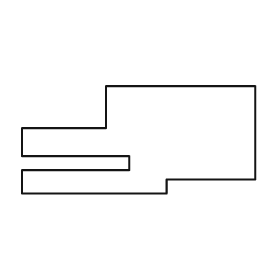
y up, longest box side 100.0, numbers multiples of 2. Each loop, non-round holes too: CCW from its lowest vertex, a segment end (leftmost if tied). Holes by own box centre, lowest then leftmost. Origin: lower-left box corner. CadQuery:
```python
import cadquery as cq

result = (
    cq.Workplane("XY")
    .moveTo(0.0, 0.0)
    .lineTo(62.0, 0.0)
    .lineTo(62.0, 6.0)
    .lineTo(100.0, 6.0)
    .lineTo(100.0, 46.0)
    .lineTo(36.0, 46.0)
    .lineTo(36.0, 28.0)
    .lineTo(0.0, 28.0)
    .lineTo(0.0, 16.0)
    .lineTo(46.0, 16.0)
    .lineTo(46.0, 10.0)
    .lineTo(0.0, 10.0)
    .close()
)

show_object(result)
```